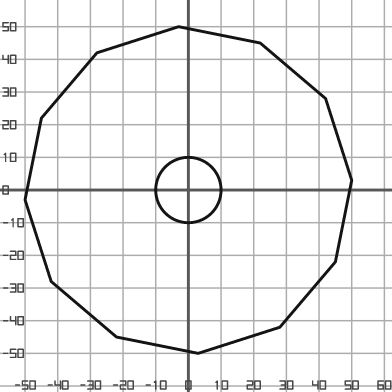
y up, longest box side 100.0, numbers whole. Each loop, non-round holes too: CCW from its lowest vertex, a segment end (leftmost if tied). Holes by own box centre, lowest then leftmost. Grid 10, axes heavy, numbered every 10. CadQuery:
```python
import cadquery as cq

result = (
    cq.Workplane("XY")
    .moveTo(3.0, -50.0)
    .lineTo(28.0, -42.0)
    .lineTo(45.0, -22.0)
    .lineTo(50.0, 3.0)
    .lineTo(42.0, 28.0)
    .lineTo(22.0, 45.0)
    .lineTo(-3.0, 50.0)
    .lineTo(-28.0, 42.0)
    .lineTo(-45.0, 22.0)
    .lineTo(-50.0, -3.0)
    .lineTo(-42.0, -28.0)
    .lineTo(-22.0, -45.0)
    .close()
    .moveTo(0.0, 0.0)
    .circle(10.0)
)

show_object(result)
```